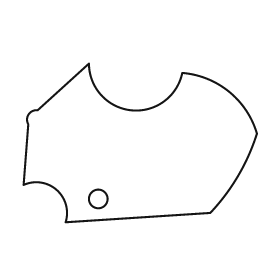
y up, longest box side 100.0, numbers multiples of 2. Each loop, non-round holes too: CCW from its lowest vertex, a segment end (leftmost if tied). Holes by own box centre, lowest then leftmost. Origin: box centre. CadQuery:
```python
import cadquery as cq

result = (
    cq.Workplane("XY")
    .moveTo(-32.0, -34.0)
    .lineTo(30.0, -30.0)
    .threePointArc((42.0, -14.0), (50.0, 4.0))
    .threePointArc((38.0, 22.0), (18.0, 30.0))
    .threePointArc((-4.0, 14.0), (-22.0, 34.0))
    .lineTo(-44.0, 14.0)
    .threePointArc((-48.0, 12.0), (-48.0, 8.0))
    .lineTo(-50.0, -18.0)
    .threePointArc((-36.0, -20.0), (-32.0, -34.0))
    .close()
    .moveTo(-18.0, -24.0)
    .circle(4.0)
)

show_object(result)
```